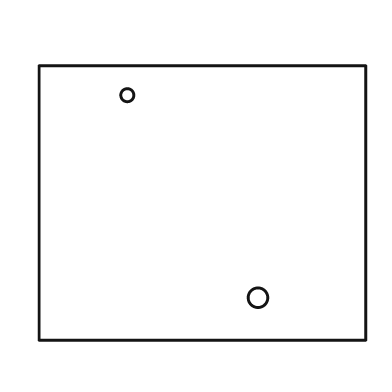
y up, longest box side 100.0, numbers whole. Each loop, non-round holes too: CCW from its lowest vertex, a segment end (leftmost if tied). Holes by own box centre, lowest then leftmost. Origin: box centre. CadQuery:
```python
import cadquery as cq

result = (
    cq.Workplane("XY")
    .moveTo(-50.0, -42.0)
    .lineTo(50.0, -42.0)
    .lineTo(50.0, 42.0)
    .lineTo(-50.0, 42.0)
    .close()
    .moveTo(17.0, -29.0)
    .circle(3.0)
    .moveTo(-23.0, 33.0)
    .circle(2.0)
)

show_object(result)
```